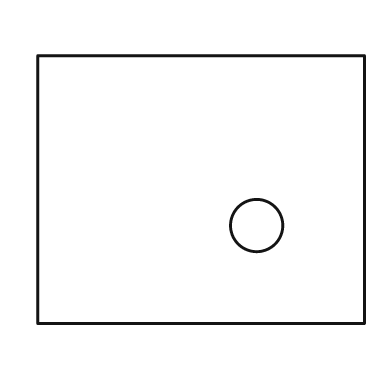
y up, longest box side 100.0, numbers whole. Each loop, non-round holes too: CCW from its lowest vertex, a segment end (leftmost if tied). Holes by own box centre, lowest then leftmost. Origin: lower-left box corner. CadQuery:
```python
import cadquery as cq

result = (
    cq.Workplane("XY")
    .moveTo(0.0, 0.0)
    .lineTo(100.0, 0.0)
    .lineTo(100.0, 82.0)
    .lineTo(0.0, 82.0)
    .close()
    .moveTo(67.0, 30.0)
    .circle(8.0)
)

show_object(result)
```